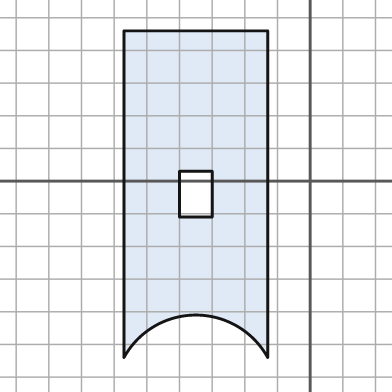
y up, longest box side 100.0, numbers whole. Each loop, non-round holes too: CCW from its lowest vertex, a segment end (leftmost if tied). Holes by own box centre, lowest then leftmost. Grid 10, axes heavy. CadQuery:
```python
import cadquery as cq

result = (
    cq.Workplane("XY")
    .moveTo(-57.0, -54.0)
    .threePointArc((-35.0, -41.0), (-13.0, -54.0))
    .lineTo(-13.0, 46.0)
    .lineTo(-57.0, 46.0)
    .close()
    .moveTo(-40.0, -11.0)
    .lineTo(-30.0, -11.0)
    .lineTo(-30.0, 3.0)
    .lineTo(-40.0, 3.0)
    .close()
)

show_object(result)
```